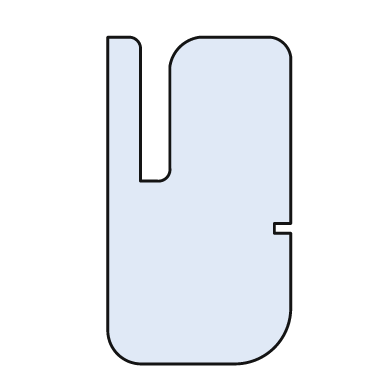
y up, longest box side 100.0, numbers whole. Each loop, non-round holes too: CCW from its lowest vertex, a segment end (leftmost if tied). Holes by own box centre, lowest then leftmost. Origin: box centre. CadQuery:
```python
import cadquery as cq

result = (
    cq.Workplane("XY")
    .moveTo(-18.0, -50.0)
    .lineTo(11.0, -50.0)
    .threePointArc((23.0, -45.0), (28.0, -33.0))
    .lineTo(28.0, -10.0)
    .lineTo(23.0, -10.0)
    .lineTo(23.0, -7.0)
    .lineTo(28.0, -7.0)
    .lineTo(28.0, 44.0)
    .threePointArc((26.0, 48.0), (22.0, 50.0))
    .lineTo(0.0, 50.0)
    .threePointArc((-6.0, 47.0), (-9.0, 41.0))
    .lineTo(-9.0, 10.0)
    .threePointArc((-10.0, 7.0), (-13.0, 6.0))
    .lineTo(-18.0, 6.0)
    .lineTo(-18.0, 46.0)
    .threePointArc((-19.0, 49.0), (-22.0, 50.0))
    .lineTo(-28.0, 50.0)
    .lineTo(-28.0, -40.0)
    .threePointArc((-25.0, -47.0), (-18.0, -50.0))
    .close()
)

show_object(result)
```